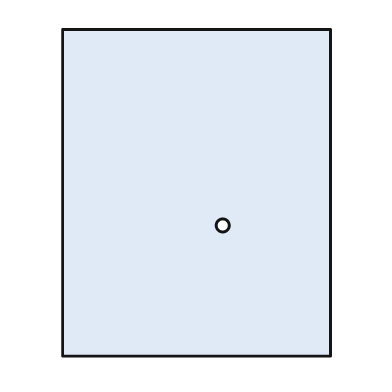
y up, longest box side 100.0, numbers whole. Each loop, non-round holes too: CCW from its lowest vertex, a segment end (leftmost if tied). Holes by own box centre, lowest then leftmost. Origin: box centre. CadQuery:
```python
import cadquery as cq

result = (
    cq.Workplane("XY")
    .moveTo(-41.0, -50.0)
    .lineTo(41.0, -50.0)
    .lineTo(41.0, 50.0)
    .lineTo(-41.0, 50.0)
    .close()
    .moveTo(8.0, -10.0)
    .circle(2.0)
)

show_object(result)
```